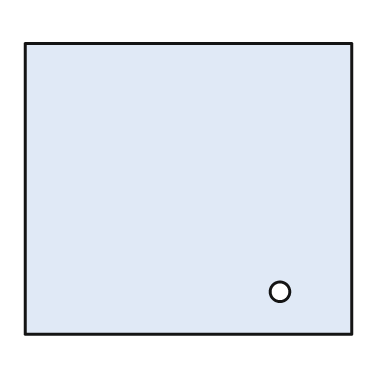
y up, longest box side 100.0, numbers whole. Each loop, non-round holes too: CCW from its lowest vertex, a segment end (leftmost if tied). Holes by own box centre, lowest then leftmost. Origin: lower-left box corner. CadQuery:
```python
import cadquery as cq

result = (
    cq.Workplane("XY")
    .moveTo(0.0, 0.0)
    .lineTo(100.0, 0.0)
    .lineTo(100.0, 89.0)
    .lineTo(0.0, 89.0)
    .close()
    .moveTo(78.0, 13.0)
    .circle(3.0)
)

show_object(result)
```